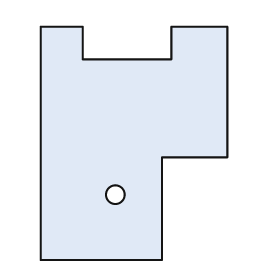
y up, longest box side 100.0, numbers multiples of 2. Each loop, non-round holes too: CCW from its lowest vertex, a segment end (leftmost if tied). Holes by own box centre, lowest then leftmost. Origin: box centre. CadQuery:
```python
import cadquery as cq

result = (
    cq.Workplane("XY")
    .moveTo(-40.0, -50.0)
    .lineTo(12.0, -50.0)
    .lineTo(12.0, -6.0)
    .lineTo(40.0, -6.0)
    .lineTo(40.0, 50.0)
    .lineTo(16.0, 50.0)
    .lineTo(16.0, 36.0)
    .lineTo(-22.0, 36.0)
    .lineTo(-22.0, 50.0)
    .lineTo(-40.0, 50.0)
    .close()
    .moveTo(-8.0, -22.0)
    .circle(4.0)
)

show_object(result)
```